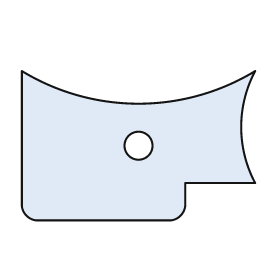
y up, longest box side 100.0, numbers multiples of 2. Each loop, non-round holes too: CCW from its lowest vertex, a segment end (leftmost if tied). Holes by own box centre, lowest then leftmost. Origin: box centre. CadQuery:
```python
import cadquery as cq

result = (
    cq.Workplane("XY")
    .moveTo(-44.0, -32.0)
    .lineTo(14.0, -32.0)
    .threePointArc((18.0, -30.0), (20.0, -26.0))
    .lineTo(20.0, -16.0)
    .lineTo(50.0, -16.0)
    .threePointArc((44.0, 8.0), (50.0, 32.0))
    .threePointArc((0.0, 18.0), (-50.0, 32.0))
    .lineTo(-50.0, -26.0)
    .threePointArc((-48.0, -30.0), (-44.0, -32.0))
    .close()
    .moveTo(0.0, 0.0)
    .circle(6.0)
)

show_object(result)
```